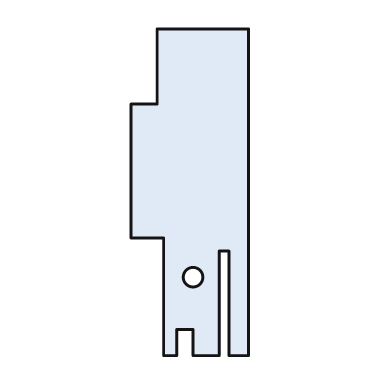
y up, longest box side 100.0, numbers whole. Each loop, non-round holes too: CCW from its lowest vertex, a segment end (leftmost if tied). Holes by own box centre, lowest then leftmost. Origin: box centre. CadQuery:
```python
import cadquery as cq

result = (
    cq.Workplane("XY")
    .moveTo(-8.0, -50.0)
    .lineTo(-4.0, -50.0)
    .lineTo(-4.0, -42.0)
    .lineTo(1.0, -42.0)
    .lineTo(1.0, -50.0)
    .lineTo(9.0, -50.0)
    .lineTo(9.0, -18.0)
    .lineTo(12.0, -18.0)
    .lineTo(12.0, -50.0)
    .lineTo(18.0, -50.0)
    .lineTo(18.0, 50.0)
    .lineTo(-10.0, 50.0)
    .lineTo(-10.0, 27.0)
    .lineTo(-18.0, 27.0)
    .lineTo(-18.0, -14.0)
    .lineTo(-8.0, -14.0)
    .close()
    .moveTo(1.0, -26.0)
    .circle(3.0)
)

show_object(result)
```